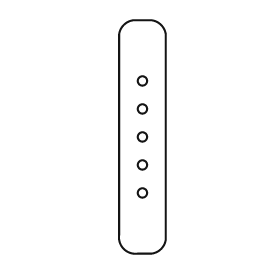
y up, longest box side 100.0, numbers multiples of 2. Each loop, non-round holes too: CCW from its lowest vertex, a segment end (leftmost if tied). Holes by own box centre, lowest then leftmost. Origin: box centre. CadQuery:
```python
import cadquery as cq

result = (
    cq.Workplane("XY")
    .moveTo(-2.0, -50.0)
    .lineTo(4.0, -50.0)
    .threePointArc((8.0, -48.0), (10.0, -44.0))
    .lineTo(10.0, 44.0)
    .threePointArc((8.0, 48.0), (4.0, 50.0))
    .lineTo(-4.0, 50.0)
    .threePointArc((-8.0, 48.0), (-10.0, 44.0))
    .lineTo(-10.0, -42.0)
    .threePointArc((-8.0, -48.0), (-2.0, -50.0))
    .close()
    .moveTo(0.0, -24.0)
    .circle(2.0)
    .moveTo(0.0, -12.0)
    .circle(2.0)
    .moveTo(0.0, 0.0)
    .circle(2.0)
    .moveTo(0.0, 12.0)
    .circle(2.0)
    .moveTo(0.0, 24.0)
    .circle(2.0)
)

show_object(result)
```